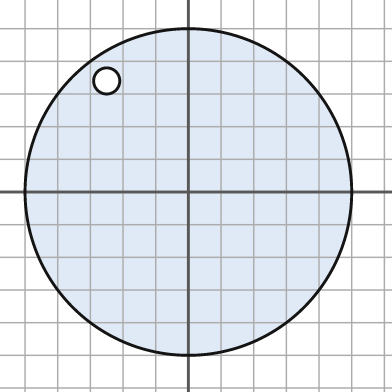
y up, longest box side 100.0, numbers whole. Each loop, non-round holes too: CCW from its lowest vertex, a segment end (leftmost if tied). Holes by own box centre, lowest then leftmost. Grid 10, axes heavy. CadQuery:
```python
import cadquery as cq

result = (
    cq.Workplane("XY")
    .moveTo(0.0, 0.0)
    .circle(50.0)
    .moveTo(-25.0, 34.0)
    .circle(4.0)
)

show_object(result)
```